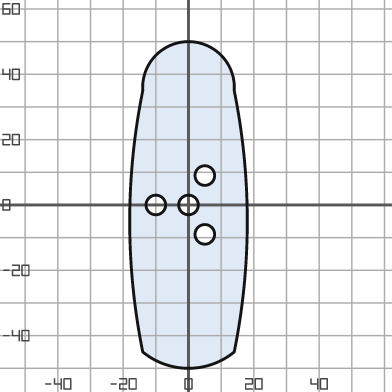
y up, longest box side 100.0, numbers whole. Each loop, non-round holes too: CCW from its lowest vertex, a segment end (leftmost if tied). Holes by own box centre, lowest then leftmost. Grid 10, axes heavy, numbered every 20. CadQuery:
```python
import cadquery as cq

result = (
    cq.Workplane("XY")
    .moveTo(-14.0, -45.0)
    .threePointArc((0.0, -50.0), (14.0, -45.0))
    .threePointArc((18.0, -5.0), (14.0, 35.0))
    .threePointArc((0.0, 50.0), (-14.0, 35.0))
    .threePointArc((-18.0, -5.0), (-14.0, -45.0))
    .close()
    .moveTo(5.0, -9.0)
    .circle(3.0)
    .moveTo(-10.0, 0.0)
    .circle(3.0)
    .moveTo(0.0, 0.0)
    .circle(3.0)
    .moveTo(5.0, 9.0)
    .circle(3.0)
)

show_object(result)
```